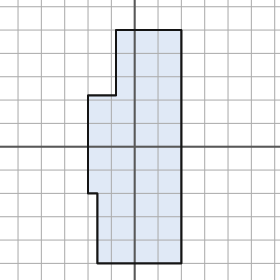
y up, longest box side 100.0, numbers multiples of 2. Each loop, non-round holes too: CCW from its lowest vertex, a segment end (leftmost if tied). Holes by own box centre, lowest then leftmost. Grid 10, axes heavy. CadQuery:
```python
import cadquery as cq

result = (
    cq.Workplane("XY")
    .moveTo(-16.0, -50.0)
    .lineTo(20.0, -50.0)
    .lineTo(20.0, 50.0)
    .lineTo(-8.0, 50.0)
    .lineTo(-8.0, 22.0)
    .lineTo(-20.0, 22.0)
    .lineTo(-20.0, -20.0)
    .lineTo(-16.0, -20.0)
    .close()
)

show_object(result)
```